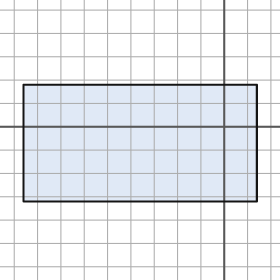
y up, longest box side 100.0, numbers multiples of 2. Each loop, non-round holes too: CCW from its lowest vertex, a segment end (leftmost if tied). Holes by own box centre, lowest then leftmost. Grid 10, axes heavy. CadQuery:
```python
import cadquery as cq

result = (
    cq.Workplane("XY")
    .moveTo(-86.0, -32.0)
    .lineTo(14.0, -32.0)
    .lineTo(14.0, 18.0)
    .lineTo(-86.0, 18.0)
    .close()
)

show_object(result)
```